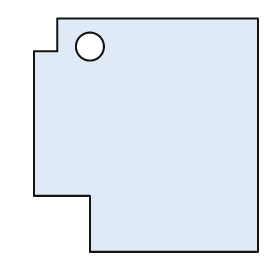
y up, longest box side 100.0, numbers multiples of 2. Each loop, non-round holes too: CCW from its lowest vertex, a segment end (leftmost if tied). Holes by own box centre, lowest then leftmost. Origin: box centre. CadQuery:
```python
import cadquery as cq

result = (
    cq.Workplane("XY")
    .moveTo(-24.0, -50.0)
    .lineTo(48.0, -50.0)
    .lineTo(48.0, 50.0)
    .lineTo(-38.0, 50.0)
    .lineTo(-38.0, 36.0)
    .lineTo(-48.0, 36.0)
    .lineTo(-48.0, -26.0)
    .lineTo(-24.0, -26.0)
    .close()
    .moveTo(-24.0, 38.0)
    .circle(6.0)
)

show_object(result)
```